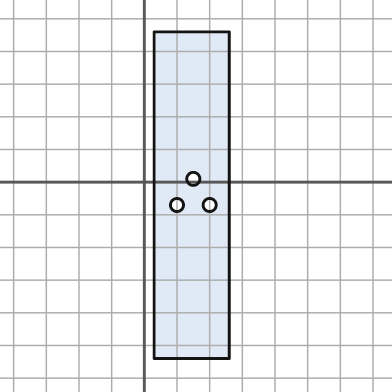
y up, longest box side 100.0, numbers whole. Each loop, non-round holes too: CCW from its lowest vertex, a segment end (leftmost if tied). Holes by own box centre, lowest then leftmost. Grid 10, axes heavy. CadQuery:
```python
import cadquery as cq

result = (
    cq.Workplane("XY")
    .moveTo(3.0, -54.0)
    .lineTo(26.0, -54.0)
    .lineTo(26.0, 46.0)
    .lineTo(3.0, 46.0)
    .close()
    .moveTo(10.0, -7.0)
    .circle(2.0)
    .moveTo(20.0, -7.0)
    .circle(2.0)
    .moveTo(15.0, 1.0)
    .circle(2.0)
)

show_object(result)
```